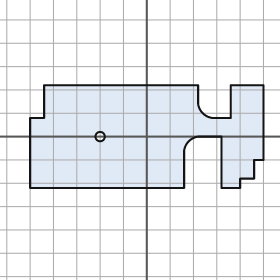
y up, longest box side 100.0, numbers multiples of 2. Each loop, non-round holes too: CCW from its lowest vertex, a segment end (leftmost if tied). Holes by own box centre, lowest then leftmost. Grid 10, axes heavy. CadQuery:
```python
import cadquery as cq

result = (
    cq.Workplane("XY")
    .moveTo(-50.0, -22.0)
    .lineTo(16.0, -22.0)
    .lineTo(16.0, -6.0)
    .threePointArc((18.0, -2.0), (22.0, 0.0))
    .lineTo(32.0, 0.0)
    .lineTo(32.0, -22.0)
    .lineTo(40.0, -22.0)
    .lineTo(40.0, -18.0)
    .lineTo(46.0, -18.0)
    .lineTo(46.0, -10.0)
    .lineTo(50.0, -10.0)
    .lineTo(50.0, 22.0)
    .lineTo(36.0, 22.0)
    .lineTo(36.0, 8.0)
    .lineTo(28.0, 8.0)
    .threePointArc((24.0, 10.0), (22.0, 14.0))
    .lineTo(22.0, 22.0)
    .lineTo(-44.0, 22.0)
    .lineTo(-44.0, 8.0)
    .lineTo(-50.0, 8.0)
    .close()
    .moveTo(-20.0, 0.0)
    .circle(2.0)
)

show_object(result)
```